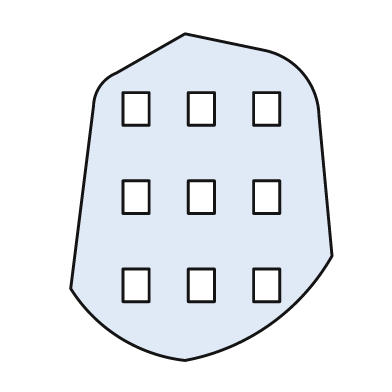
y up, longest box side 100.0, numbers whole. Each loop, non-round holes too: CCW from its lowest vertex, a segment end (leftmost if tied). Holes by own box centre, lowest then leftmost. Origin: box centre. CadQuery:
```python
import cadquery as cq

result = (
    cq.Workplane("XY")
    .moveTo(-5.0, -50.0)
    .threePointArc((21.0, -39.0), (40.0, -18.0))
    .lineTo(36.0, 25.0)
    .threePointArc((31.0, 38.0), (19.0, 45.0))
    .lineTo(-5.0, 50.0)
    .lineTo(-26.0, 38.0)
    .threePointArc((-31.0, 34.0), (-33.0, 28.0))
    .lineTo(-40.0, -28.0)
    .threePointArc((-25.0, -43.0), (-5.0, -50.0))
    .close()
    .moveTo(-24.0, -32.0)
    .lineTo(-16.0, -32.0)
    .lineTo(-16.0, -22.0)
    .lineTo(-24.0, -22.0)
    .close()
    .moveTo(-4.0, -32.0)
    .lineTo(4.0, -32.0)
    .lineTo(4.0, -22.0)
    .lineTo(-4.0, -22.0)
    .close()
    .moveTo(16.0, -32.0)
    .lineTo(24.0, -32.0)
    .lineTo(24.0, -22.0)
    .lineTo(16.0, -22.0)
    .close()
    .moveTo(-24.0, -5.0)
    .lineTo(-16.0, -5.0)
    .lineTo(-16.0, 5.0)
    .lineTo(-24.0, 5.0)
    .close()
    .moveTo(-4.0, -5.0)
    .lineTo(4.0, -5.0)
    .lineTo(4.0, 5.0)
    .lineTo(-4.0, 5.0)
    .close()
    .moveTo(16.0, -5.0)
    .lineTo(24.0, -5.0)
    .lineTo(24.0, 5.0)
    .lineTo(16.0, 5.0)
    .close()
    .moveTo(-24.0, 22.0)
    .lineTo(-16.0, 22.0)
    .lineTo(-16.0, 32.0)
    .lineTo(-24.0, 32.0)
    .close()
    .moveTo(-4.0, 22.0)
    .lineTo(4.0, 22.0)
    .lineTo(4.0, 32.0)
    .lineTo(-4.0, 32.0)
    .close()
    .moveTo(16.0, 22.0)
    .lineTo(24.0, 22.0)
    .lineTo(24.0, 32.0)
    .lineTo(16.0, 32.0)
    .close()
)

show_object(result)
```